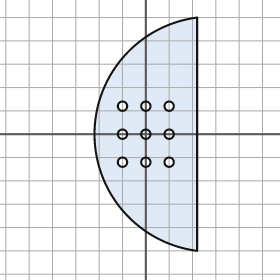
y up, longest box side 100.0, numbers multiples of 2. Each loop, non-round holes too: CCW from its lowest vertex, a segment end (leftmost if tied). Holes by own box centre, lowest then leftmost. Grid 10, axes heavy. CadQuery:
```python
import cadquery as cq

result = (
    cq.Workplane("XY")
    .moveTo(22.0, -50.0)
    .lineTo(22.0, 50.0)
    .threePointArc((-22.0, 0.0), (22.0, -50.0))
    .close()
    .moveTo(-10.0, -12.0)
    .circle(2.0)
    .moveTo(0.0, -12.0)
    .circle(2.0)
    .moveTo(10.0, -12.0)
    .circle(2.0)
    .moveTo(-10.0, 0.0)
    .circle(2.0)
    .moveTo(0.0, 0.0)
    .circle(2.0)
    .moveTo(10.0, 0.0)
    .circle(2.0)
    .moveTo(-10.0, 12.0)
    .circle(2.0)
    .moveTo(0.0, 12.0)
    .circle(2.0)
    .moveTo(10.0, 12.0)
    .circle(2.0)
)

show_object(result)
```